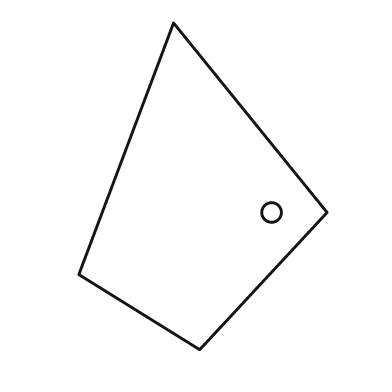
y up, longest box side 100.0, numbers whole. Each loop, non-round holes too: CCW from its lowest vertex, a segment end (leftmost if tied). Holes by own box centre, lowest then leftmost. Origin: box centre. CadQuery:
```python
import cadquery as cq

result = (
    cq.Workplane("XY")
    .moveTo(-1.0, -50.0)
    .lineTo(38.0, -8.0)
    .lineTo(-9.0, 50.0)
    .lineTo(-38.0, -27.0)
    .close()
    .moveTo(21.0, -8.0)
    .circle(3.0)
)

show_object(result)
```